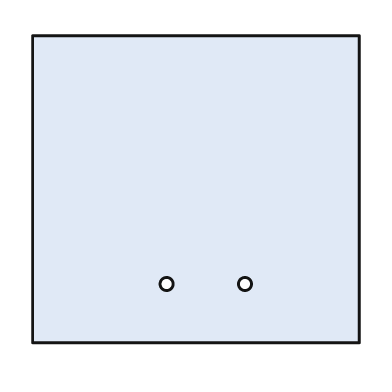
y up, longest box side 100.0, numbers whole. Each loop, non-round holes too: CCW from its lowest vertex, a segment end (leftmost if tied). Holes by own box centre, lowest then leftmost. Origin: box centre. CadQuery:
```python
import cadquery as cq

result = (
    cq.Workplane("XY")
    .moveTo(-50.0, -47.0)
    .lineTo(50.0, -47.0)
    .lineTo(50.0, 47.0)
    .lineTo(-50.0, 47.0)
    .close()
    .moveTo(-9.0, -29.0)
    .circle(2.0)
    .moveTo(15.0, -29.0)
    .circle(2.0)
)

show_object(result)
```